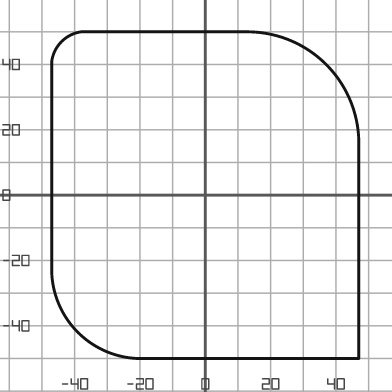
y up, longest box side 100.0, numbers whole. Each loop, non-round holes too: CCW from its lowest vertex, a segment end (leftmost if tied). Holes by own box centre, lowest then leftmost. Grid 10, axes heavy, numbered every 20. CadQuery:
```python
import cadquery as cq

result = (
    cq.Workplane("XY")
    .moveTo(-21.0, -50.0)
    .lineTo(47.0, -50.0)
    .lineTo(47.0, 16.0)
    .threePointArc((37.0, 40.0), (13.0, 50.0))
    .lineTo(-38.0, 50.0)
    .threePointArc((-44.0, 47.0), (-47.0, 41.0))
    .lineTo(-47.0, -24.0)
    .threePointArc((-39.0, -42.0), (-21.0, -50.0))
    .close()
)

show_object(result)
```